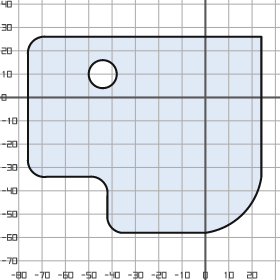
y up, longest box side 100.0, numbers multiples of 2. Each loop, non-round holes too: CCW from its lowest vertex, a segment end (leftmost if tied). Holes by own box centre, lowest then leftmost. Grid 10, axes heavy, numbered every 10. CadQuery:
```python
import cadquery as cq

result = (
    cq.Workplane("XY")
    .moveTo(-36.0, -58.0)
    .lineTo(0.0, -58.0)
    .threePointArc((16.0, -50.0), (24.0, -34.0))
    .lineTo(24.0, 26.0)
    .lineTo(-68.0, 26.0)
    .threePointArc((-74.0, 24.0), (-76.0, 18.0))
    .lineTo(-76.0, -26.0)
    .threePointArc((-74.0, -32.0), (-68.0, -34.0))
    .lineTo(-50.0, -34.0)
    .threePointArc((-44.0, -36.0), (-42.0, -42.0))
    .lineTo(-42.0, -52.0)
    .threePointArc((-40.0, -56.0), (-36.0, -58.0))
    .close()
    .moveTo(-44.0, 10.0)
    .circle(6.0)
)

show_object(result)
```